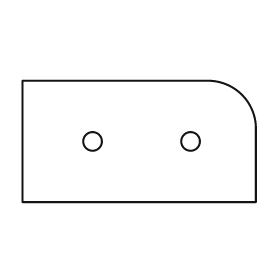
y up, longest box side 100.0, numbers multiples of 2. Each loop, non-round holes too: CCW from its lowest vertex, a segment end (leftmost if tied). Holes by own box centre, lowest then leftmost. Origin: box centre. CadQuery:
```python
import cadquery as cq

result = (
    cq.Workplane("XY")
    .moveTo(-50.0, -26.0)
    .lineTo(50.0, -26.0)
    .lineTo(50.0, 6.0)
    .threePointArc((44.0, 20.0), (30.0, 26.0))
    .lineTo(-50.0, 26.0)
    .close()
    .moveTo(-20.0, 0.0)
    .circle(4.0)
    .moveTo(22.0, 0.0)
    .circle(4.0)
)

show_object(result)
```